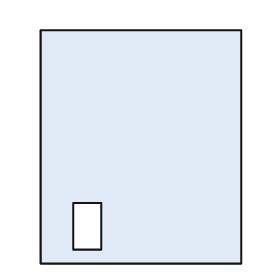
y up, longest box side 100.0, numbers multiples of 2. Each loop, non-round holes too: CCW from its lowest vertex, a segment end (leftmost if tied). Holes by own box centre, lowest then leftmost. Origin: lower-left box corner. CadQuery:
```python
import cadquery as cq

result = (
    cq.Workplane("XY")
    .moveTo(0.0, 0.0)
    .lineTo(86.0, 0.0)
    .lineTo(86.0, 100.0)
    .lineTo(0.0, 100.0)
    .close()
    .moveTo(14.0, 6.0)
    .lineTo(26.0, 6.0)
    .lineTo(26.0, 26.0)
    .lineTo(14.0, 26.0)
    .close()
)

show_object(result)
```